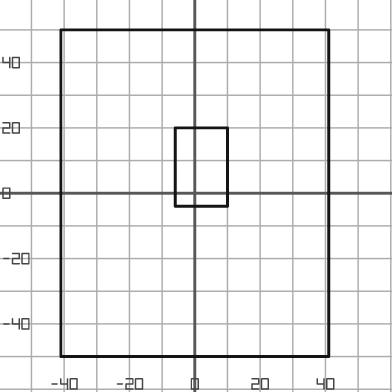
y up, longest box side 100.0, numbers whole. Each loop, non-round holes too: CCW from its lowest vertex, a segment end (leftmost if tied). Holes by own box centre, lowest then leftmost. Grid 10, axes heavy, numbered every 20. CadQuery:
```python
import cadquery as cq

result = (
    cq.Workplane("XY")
    .moveTo(-41.0, -50.0)
    .lineTo(41.0, -50.0)
    .lineTo(41.0, 50.0)
    .lineTo(-41.0, 50.0)
    .close()
    .moveTo(-6.0, -4.0)
    .lineTo(10.0, -4.0)
    .lineTo(10.0, 20.0)
    .lineTo(-6.0, 20.0)
    .close()
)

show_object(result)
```